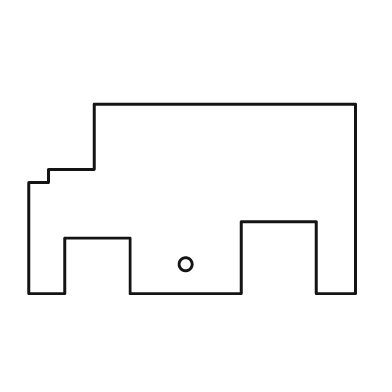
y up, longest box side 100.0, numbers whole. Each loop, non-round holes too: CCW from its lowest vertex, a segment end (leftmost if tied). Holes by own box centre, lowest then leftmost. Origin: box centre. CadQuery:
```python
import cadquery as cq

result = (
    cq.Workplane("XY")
    .moveTo(-50.0, -29.0)
    .lineTo(-39.0, -29.0)
    .lineTo(-39.0, -12.0)
    .lineTo(-19.0, -12.0)
    .lineTo(-19.0, -29.0)
    .lineTo(15.0, -29.0)
    .lineTo(15.0, -7.0)
    .lineTo(38.0, -7.0)
    .lineTo(38.0, -29.0)
    .lineTo(50.0, -29.0)
    .lineTo(50.0, 29.0)
    .lineTo(-30.0, 29.0)
    .lineTo(-30.0, 9.0)
    .lineTo(-44.0, 9.0)
    .lineTo(-44.0, 5.0)
    .lineTo(-50.0, 5.0)
    .close()
    .moveTo(-2.0, -20.0)
    .circle(2.0)
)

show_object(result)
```